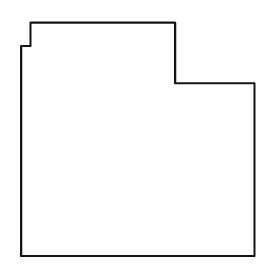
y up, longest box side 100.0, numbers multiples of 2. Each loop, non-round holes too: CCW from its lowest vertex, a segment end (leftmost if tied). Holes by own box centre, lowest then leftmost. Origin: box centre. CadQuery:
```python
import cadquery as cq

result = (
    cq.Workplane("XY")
    .moveTo(-50.0, -50.0)
    .lineTo(50.0, -50.0)
    .lineTo(50.0, 24.0)
    .lineTo(16.0, 24.0)
    .lineTo(16.0, 50.0)
    .lineTo(-46.0, 50.0)
    .lineTo(-46.0, 40.0)
    .lineTo(-50.0, 40.0)
    .close()
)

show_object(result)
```